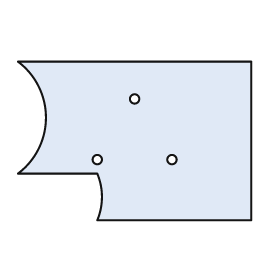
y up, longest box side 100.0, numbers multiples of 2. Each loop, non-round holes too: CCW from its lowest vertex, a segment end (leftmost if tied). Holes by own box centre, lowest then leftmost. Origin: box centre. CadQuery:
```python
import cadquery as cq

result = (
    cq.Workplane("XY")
    .moveTo(-16.0, -34.0)
    .lineTo(50.0, -34.0)
    .lineTo(50.0, 34.0)
    .lineTo(-50.0, 34.0)
    .threePointArc((-38.0, 10.0), (-50.0, -14.0))
    .lineTo(-16.0, -14.0)
    .threePointArc((-14.0, -24.0), (-16.0, -34.0))
    .close()
    .moveTo(-16.0, -8.0)
    .circle(2.0)
    .moveTo(16.0, -8.0)
    .circle(2.0)
    .moveTo(0.0, 18.0)
    .circle(2.0)
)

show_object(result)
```